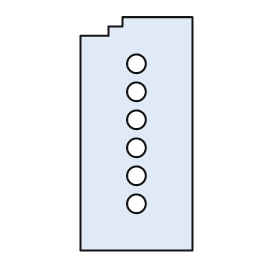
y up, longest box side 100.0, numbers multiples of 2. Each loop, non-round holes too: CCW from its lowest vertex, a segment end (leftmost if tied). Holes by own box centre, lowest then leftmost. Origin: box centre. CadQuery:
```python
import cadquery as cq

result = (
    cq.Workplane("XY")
    .moveTo(-24.0, -50.0)
    .lineTo(24.0, -50.0)
    .lineTo(24.0, 50.0)
    .lineTo(-6.0, 50.0)
    .lineTo(-6.0, 46.0)
    .lineTo(-12.0, 46.0)
    .lineTo(-12.0, 42.0)
    .lineTo(-24.0, 42.0)
    .close()
    .moveTo(0.0, -30.0)
    .circle(4.0)
    .moveTo(0.0, -18.0)
    .circle(4.0)
    .moveTo(0.0, -6.0)
    .circle(4.0)
    .moveTo(0.0, 6.0)
    .circle(4.0)
    .moveTo(0.0, 18.0)
    .circle(4.0)
    .moveTo(0.0, 30.0)
    .circle(4.0)
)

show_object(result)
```